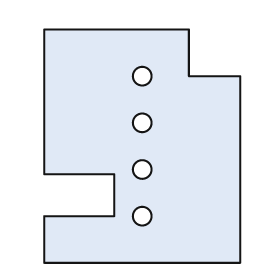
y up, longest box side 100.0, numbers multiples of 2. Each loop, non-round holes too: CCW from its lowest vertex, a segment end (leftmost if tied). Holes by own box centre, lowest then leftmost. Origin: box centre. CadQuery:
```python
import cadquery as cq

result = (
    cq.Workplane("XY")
    .moveTo(-42.0, -50.0)
    .lineTo(42.0, -50.0)
    .lineTo(42.0, 30.0)
    .lineTo(20.0, 30.0)
    .lineTo(20.0, 50.0)
    .lineTo(-42.0, 50.0)
    .lineTo(-42.0, -12.0)
    .lineTo(-12.0, -12.0)
    .lineTo(-12.0, -30.0)
    .lineTo(-42.0, -30.0)
    .close()
    .moveTo(0.0, -30.0)
    .circle(4.0)
    .moveTo(0.0, -10.0)
    .circle(4.0)
    .moveTo(0.0, 10.0)
    .circle(4.0)
    .moveTo(0.0, 30.0)
    .circle(4.0)
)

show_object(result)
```